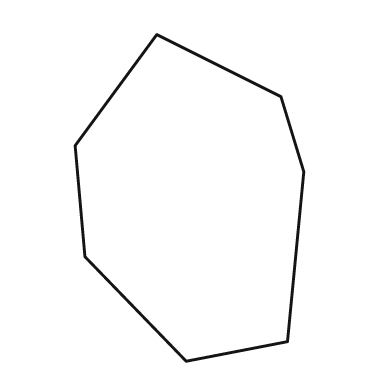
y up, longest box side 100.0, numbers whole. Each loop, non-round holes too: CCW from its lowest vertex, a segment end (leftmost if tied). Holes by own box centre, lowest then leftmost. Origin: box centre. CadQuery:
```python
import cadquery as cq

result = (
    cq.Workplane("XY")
    .moveTo(-1.0, -50.0)
    .lineTo(30.0, -44.0)
    .lineTo(35.0, 8.0)
    .lineTo(28.0, 31.0)
    .lineTo(-10.0, 50.0)
    .lineTo(-35.0, 16.0)
    .lineTo(-32.0, -18.0)
    .close()
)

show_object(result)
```